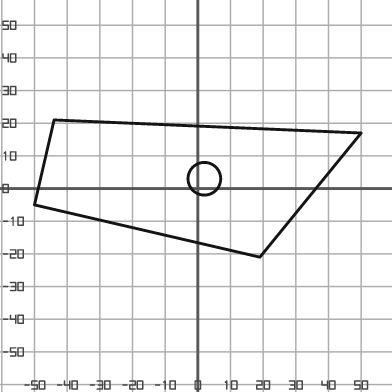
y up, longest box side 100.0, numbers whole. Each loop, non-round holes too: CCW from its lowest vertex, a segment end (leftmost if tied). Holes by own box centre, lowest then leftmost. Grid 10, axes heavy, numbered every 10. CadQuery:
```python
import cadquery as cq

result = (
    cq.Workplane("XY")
    .moveTo(19.0, -21.0)
    .lineTo(50.0, 17.0)
    .lineTo(-44.0, 21.0)
    .lineTo(-50.0, -5.0)
    .close()
    .moveTo(2.0, 3.0)
    .circle(5.0)
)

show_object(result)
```